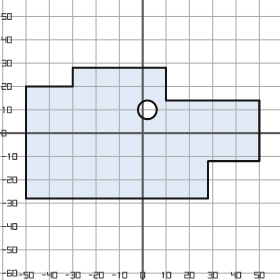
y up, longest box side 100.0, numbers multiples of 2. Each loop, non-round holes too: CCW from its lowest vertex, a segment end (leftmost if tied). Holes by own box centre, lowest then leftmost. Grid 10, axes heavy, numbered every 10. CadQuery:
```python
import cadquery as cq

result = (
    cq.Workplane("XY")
    .moveTo(-50.0, -28.0)
    .lineTo(28.0, -28.0)
    .lineTo(28.0, -12.0)
    .lineTo(50.0, -12.0)
    .lineTo(50.0, 14.0)
    .lineTo(10.0, 14.0)
    .lineTo(10.0, 28.0)
    .lineTo(-30.0, 28.0)
    .lineTo(-30.0, 20.0)
    .lineTo(-50.0, 20.0)
    .close()
    .moveTo(2.0, 10.0)
    .circle(4.0)
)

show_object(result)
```